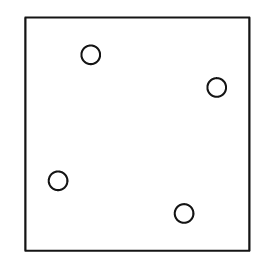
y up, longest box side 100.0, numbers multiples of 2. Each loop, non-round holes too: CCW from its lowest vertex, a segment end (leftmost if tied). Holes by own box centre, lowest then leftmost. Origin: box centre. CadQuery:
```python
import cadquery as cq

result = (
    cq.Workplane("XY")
    .moveTo(-48.0, -50.0)
    .lineTo(48.0, -50.0)
    .lineTo(48.0, 50.0)
    .lineTo(-48.0, 50.0)
    .close()
    .moveTo(20.0, -34.0)
    .circle(4.0)
    .moveTo(-34.0, -20.0)
    .circle(4.0)
    .moveTo(34.0, 20.0)
    .circle(4.0)
    .moveTo(-20.0, 34.0)
    .circle(4.0)
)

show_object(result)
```